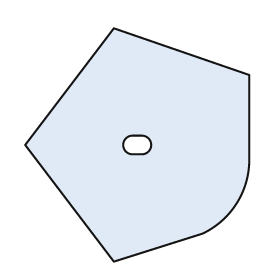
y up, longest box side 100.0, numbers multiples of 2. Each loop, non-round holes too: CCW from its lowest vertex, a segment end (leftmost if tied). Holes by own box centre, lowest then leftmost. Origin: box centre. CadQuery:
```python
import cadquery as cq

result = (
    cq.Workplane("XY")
    .moveTo(-10.0, -50.0)
    .lineTo(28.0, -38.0)
    .threePointArc((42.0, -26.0), (48.0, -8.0))
    .lineTo(48.0, 30.0)
    .lineTo(-10.0, 50.0)
    .lineTo(-48.0, 0.0)
    .close()
    .moveTo(-2.0, -4.0)
    .lineTo(2.0, -4.0)
    .threePointArc((6.0, 0.0), (2.0, 4.0))
    .lineTo(-2.0, 4.0)
    .threePointArc((-6.0, 0.0), (-2.0, -4.0))
    .close()
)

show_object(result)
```